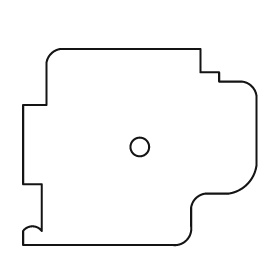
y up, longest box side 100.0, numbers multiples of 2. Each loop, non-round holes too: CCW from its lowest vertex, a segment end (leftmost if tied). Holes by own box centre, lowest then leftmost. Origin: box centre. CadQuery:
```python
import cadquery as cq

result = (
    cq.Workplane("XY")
    .moveTo(-50.0, -42.0)
    .lineTo(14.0, -42.0)
    .threePointArc((20.0, -40.0), (22.0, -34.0))
    .lineTo(22.0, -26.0)
    .threePointArc((24.0, -22.0), (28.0, -20.0))
    .lineTo(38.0, -20.0)
    .threePointArc((46.0, -16.0), (50.0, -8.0))
    .lineTo(50.0, 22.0)
    .threePointArc((48.0, 26.0), (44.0, 28.0))
    .lineTo(34.0, 28.0)
    .lineTo(34.0, 32.0)
    .lineTo(26.0, 32.0)
    .lineTo(26.0, 42.0)
    .lineTo(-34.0, 42.0)
    .threePointArc((-38.0, 40.0), (-40.0, 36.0))
    .lineTo(-40.0, 18.0)
    .lineTo(-50.0, 18.0)
    .lineTo(-50.0, -16.0)
    .lineTo(-42.0, -16.0)
    .lineTo(-42.0, -36.0)
    .threePointArc((-46.0, -34.0), (-50.0, -36.0))
    .close()
    .moveTo(0.0, 0.0)
    .circle(4.0)
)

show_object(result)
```